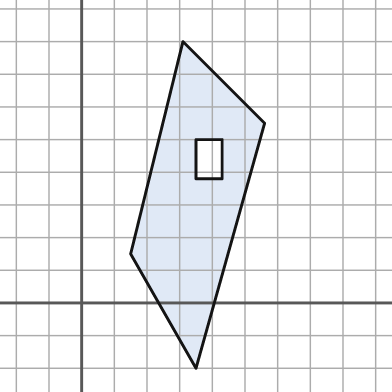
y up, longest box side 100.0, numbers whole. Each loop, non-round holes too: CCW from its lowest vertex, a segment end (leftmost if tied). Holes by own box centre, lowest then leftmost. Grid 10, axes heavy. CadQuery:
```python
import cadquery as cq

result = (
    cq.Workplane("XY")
    .moveTo(35.0, -20.0)
    .lineTo(56.0, 55.0)
    .lineTo(31.0, 80.0)
    .lineTo(15.0, 15.0)
    .close()
    .moveTo(35.0, 38.0)
    .lineTo(43.0, 38.0)
    .lineTo(43.0, 50.0)
    .lineTo(35.0, 50.0)
    .close()
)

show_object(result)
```